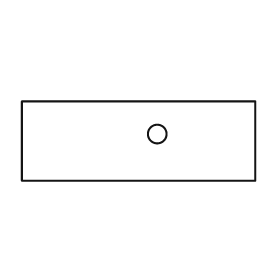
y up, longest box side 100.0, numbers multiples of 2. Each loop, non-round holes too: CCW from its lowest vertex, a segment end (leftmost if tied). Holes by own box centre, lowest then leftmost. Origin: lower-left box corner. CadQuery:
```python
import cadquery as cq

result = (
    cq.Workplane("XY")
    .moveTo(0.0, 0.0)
    .lineTo(100.0, 0.0)
    .lineTo(100.0, 34.0)
    .lineTo(0.0, 34.0)
    .close()
    .moveTo(58.0, 20.0)
    .circle(4.0)
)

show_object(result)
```